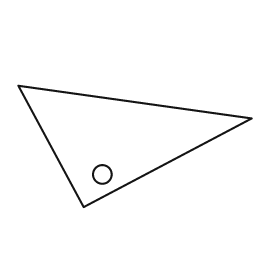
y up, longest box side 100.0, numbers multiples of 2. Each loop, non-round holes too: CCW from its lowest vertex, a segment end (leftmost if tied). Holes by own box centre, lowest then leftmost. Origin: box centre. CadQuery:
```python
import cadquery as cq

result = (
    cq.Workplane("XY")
    .moveTo(-22.0, -26.0)
    .lineTo(50.0, 12.0)
    .lineTo(-50.0, 26.0)
    .close()
    .moveTo(-14.0, -12.0)
    .circle(4.0)
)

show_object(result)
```